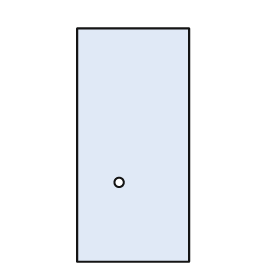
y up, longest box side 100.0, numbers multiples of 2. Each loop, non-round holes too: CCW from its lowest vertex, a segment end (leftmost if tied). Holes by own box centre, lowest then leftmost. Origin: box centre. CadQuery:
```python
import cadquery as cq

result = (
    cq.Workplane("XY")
    .moveTo(-24.0, -50.0)
    .lineTo(24.0, -50.0)
    .lineTo(24.0, 50.0)
    .lineTo(-24.0, 50.0)
    .close()
    .moveTo(-6.0, -16.0)
    .circle(2.0)
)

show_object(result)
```